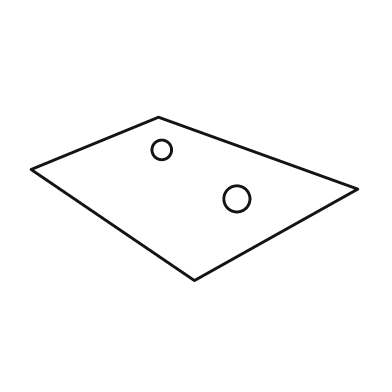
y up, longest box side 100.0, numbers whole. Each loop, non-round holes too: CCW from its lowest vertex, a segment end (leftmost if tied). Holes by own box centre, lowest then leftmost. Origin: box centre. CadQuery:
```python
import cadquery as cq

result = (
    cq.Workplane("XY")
    .moveTo(0.0, -25.0)
    .lineTo(50.0, 3.0)
    .lineTo(-11.0, 25.0)
    .lineTo(-50.0, 9.0)
    .close()
    .moveTo(13.0, 0.0)
    .circle(4.0)
    .moveTo(-10.0, 15.0)
    .circle(3.0)
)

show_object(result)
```